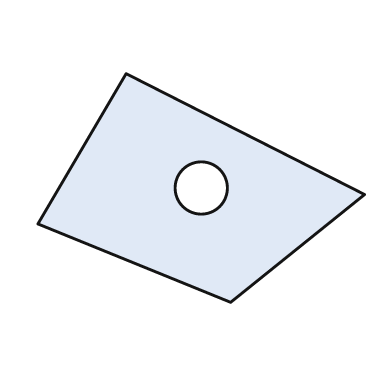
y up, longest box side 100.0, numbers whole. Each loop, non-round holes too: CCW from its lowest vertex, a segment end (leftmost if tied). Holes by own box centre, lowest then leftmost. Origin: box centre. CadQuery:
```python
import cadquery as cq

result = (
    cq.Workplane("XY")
    .moveTo(9.0, -35.0)
    .lineTo(50.0, -2.0)
    .lineTo(-23.0, 35.0)
    .lineTo(-50.0, -11.0)
    .close()
    .moveTo(0.0, 0.0)
    .circle(8.0)
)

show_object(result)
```